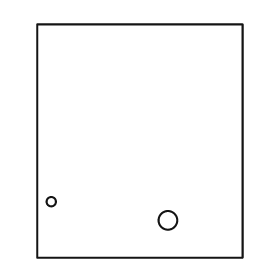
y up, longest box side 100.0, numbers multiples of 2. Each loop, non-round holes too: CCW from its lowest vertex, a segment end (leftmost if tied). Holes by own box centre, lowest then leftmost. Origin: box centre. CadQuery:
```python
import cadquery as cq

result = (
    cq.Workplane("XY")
    .moveTo(-44.0, -50.0)
    .lineTo(44.0, -50.0)
    .lineTo(44.0, 50.0)
    .lineTo(-44.0, 50.0)
    .close()
    .moveTo(12.0, -34.0)
    .circle(4.0)
    .moveTo(-38.0, -26.0)
    .circle(2.0)
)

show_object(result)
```